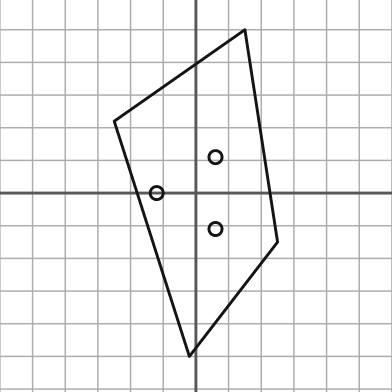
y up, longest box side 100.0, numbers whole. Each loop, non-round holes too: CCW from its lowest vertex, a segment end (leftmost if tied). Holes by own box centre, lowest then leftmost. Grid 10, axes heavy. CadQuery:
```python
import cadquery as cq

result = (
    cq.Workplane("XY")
    .moveTo(-2.0, -50.0)
    .lineTo(25.0, -15.0)
    .lineTo(15.0, 50.0)
    .lineTo(-25.0, 22.0)
    .close()
    .moveTo(6.0, -11.0)
    .circle(2.0)
    .moveTo(-12.0, 0.0)
    .circle(2.0)
    .moveTo(6.0, 11.0)
    .circle(2.0)
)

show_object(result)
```